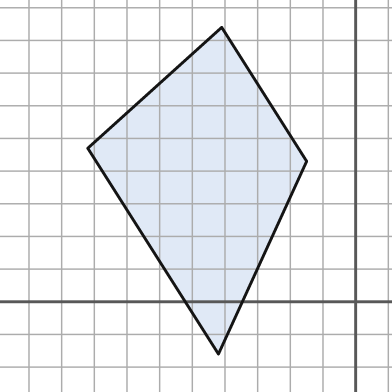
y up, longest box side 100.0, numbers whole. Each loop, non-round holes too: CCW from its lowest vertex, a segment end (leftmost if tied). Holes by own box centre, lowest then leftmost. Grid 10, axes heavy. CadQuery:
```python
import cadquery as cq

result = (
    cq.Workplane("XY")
    .moveTo(-42.0, -16.0)
    .lineTo(-15.0, 43.0)
    .lineTo(-41.0, 84.0)
    .lineTo(-82.0, 47.0)
    .close()
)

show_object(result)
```